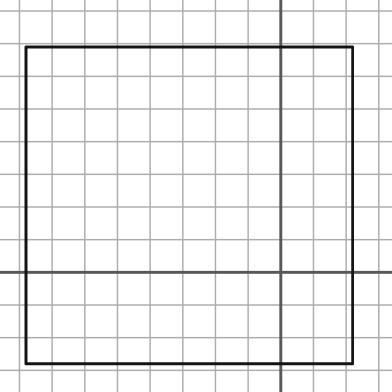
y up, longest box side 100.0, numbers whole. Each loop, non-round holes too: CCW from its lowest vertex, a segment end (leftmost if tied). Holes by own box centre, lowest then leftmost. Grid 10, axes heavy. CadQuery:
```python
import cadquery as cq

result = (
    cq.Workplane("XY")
    .moveTo(-78.0, -28.0)
    .lineTo(22.0, -28.0)
    .lineTo(22.0, 69.0)
    .lineTo(-78.0, 69.0)
    .close()
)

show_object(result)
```